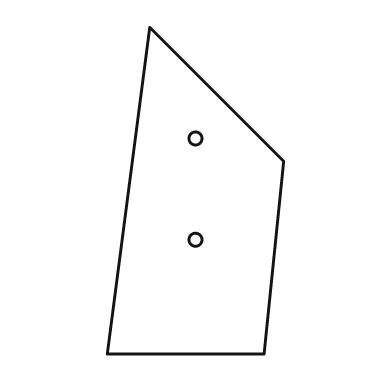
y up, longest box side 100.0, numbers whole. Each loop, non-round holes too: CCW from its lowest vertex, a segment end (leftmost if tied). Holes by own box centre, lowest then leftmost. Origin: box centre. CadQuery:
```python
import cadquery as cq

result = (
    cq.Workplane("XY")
    .moveTo(-27.0, -50.0)
    .lineTo(21.0, -50.0)
    .lineTo(27.0, 9.0)
    .lineTo(-14.0, 50.0)
    .close()
    .moveTo(0.0, -15.0)
    .circle(2.0)
    .moveTo(0.0, 16.0)
    .circle(2.0)
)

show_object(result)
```